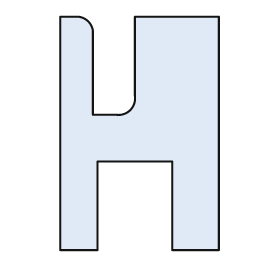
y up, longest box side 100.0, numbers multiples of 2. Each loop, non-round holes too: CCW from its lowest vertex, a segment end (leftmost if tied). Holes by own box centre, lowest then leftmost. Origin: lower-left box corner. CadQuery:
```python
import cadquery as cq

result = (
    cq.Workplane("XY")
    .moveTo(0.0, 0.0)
    .lineTo(16.0, 0.0)
    .lineTo(16.0, 38.0)
    .lineTo(48.0, 38.0)
    .lineTo(48.0, 0.0)
    .lineTo(68.0, 0.0)
    .lineTo(68.0, 100.0)
    .lineTo(32.0, 100.0)
    .lineTo(32.0, 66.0)
    .threePointArc((30.0, 60.0), (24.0, 58.0))
    .lineTo(14.0, 58.0)
    .lineTo(14.0, 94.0)
    .threePointArc((12.0, 98.0), (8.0, 100.0))
    .lineTo(0.0, 100.0)
    .close()
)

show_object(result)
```